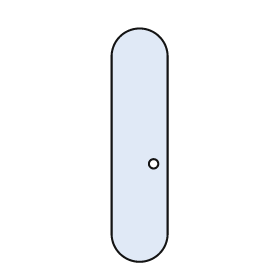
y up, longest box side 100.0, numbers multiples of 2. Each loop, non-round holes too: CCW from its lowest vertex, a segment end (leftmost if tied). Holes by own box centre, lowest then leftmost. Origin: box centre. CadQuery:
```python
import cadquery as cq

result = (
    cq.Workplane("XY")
    .moveTo(-12.0, -38.0)
    .threePointArc((0.0, -50.0), (12.0, -38.0))
    .lineTo(12.0, 38.0)
    .threePointArc((0.0, 50.0), (-12.0, 38.0))
    .close()
    .moveTo(6.0, -8.0)
    .circle(2.0)
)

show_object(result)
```